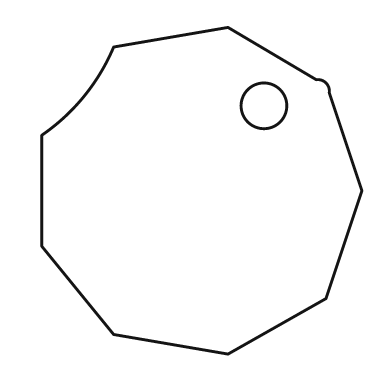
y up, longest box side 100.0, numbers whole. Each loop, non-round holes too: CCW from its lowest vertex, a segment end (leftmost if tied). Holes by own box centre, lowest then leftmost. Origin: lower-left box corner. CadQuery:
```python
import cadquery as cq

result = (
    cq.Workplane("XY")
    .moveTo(57.0, 0.0)
    .lineTo(87.0, 17.0)
    .lineTo(98.0, 50.0)
    .lineTo(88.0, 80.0)
    .threePointArc((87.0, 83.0), (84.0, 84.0))
    .lineTo(57.0, 100.0)
    .lineTo(22.0, 94.0)
    .threePointArc((13.0, 79.0), (0.0, 67.0))
    .lineTo(0.0, 33.0)
    .lineTo(22.0, 6.0)
    .close()
    .moveTo(68.0, 76.0)
    .circle(7.0)
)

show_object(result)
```